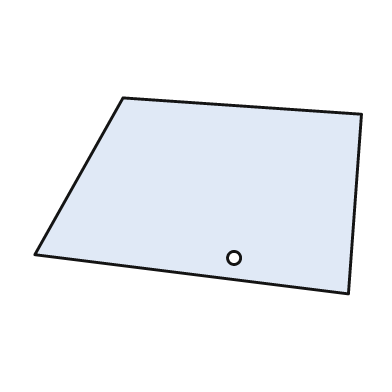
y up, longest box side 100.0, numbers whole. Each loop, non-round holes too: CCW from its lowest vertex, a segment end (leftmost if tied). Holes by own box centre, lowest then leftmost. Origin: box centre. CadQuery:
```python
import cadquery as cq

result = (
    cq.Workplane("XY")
    .moveTo(46.0, -30.0)
    .lineTo(50.0, 25.0)
    .lineTo(-23.0, 30.0)
    .lineTo(-50.0, -18.0)
    .close()
    .moveTo(11.0, -19.0)
    .circle(2.0)
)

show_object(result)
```